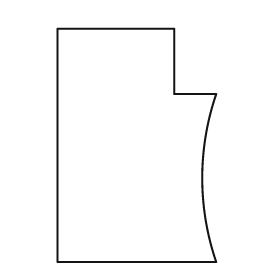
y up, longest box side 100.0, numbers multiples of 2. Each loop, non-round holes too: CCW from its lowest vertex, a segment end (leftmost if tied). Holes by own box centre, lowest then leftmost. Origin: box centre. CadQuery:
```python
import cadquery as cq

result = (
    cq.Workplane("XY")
    .moveTo(-34.0, -50.0)
    .lineTo(34.0, -50.0)
    .threePointArc((28.0, -14.0), (34.0, 22.0))
    .lineTo(16.0, 22.0)
    .lineTo(16.0, 50.0)
    .lineTo(-34.0, 50.0)
    .close()
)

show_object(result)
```